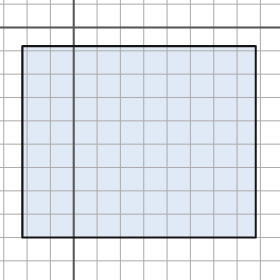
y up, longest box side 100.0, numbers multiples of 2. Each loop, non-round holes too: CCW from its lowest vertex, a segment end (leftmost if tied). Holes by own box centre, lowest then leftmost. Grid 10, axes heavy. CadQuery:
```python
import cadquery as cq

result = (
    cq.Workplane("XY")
    .moveTo(-22.0, -90.0)
    .lineTo(78.0, -90.0)
    .lineTo(78.0, -8.0)
    .lineTo(-22.0, -8.0)
    .close()
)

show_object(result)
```